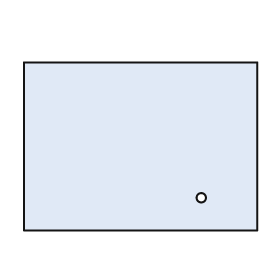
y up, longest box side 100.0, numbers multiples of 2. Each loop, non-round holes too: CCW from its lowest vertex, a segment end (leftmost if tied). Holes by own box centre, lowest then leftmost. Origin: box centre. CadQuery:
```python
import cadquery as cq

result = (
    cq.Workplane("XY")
    .moveTo(-50.0, -36.0)
    .lineTo(50.0, -36.0)
    .lineTo(50.0, 36.0)
    .lineTo(-50.0, 36.0)
    .close()
    .moveTo(26.0, -22.0)
    .circle(2.0)
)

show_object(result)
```